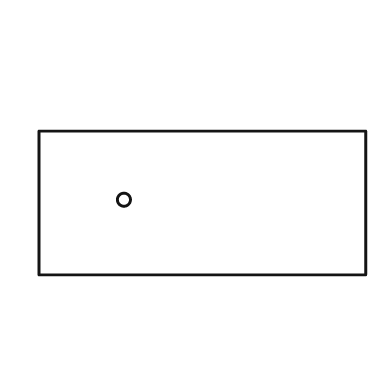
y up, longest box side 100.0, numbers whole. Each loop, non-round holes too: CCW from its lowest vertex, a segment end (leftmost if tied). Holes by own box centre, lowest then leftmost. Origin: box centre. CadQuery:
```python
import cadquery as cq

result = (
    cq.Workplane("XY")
    .moveTo(-50.0, -22.0)
    .lineTo(50.0, -22.0)
    .lineTo(50.0, 22.0)
    .lineTo(-50.0, 22.0)
    .close()
    .moveTo(-24.0, 1.0)
    .circle(2.0)
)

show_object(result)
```